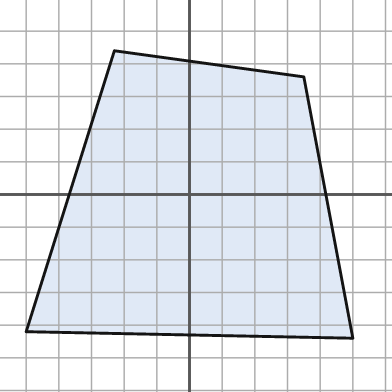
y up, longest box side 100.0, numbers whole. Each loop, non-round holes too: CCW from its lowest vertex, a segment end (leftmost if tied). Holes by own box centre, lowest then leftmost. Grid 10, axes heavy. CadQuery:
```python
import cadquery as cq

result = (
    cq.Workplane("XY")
    .moveTo(50.0, -44.0)
    .lineTo(35.0, 36.0)
    .lineTo(-23.0, 44.0)
    .lineTo(-50.0, -42.0)
    .close()
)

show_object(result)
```